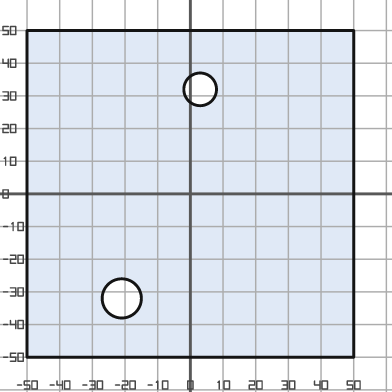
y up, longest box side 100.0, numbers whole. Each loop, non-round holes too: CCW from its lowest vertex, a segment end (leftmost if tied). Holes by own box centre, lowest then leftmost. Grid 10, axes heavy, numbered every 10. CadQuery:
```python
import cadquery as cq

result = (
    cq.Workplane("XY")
    .moveTo(-50.0, -50.0)
    .lineTo(50.0, -50.0)
    .lineTo(50.0, 50.0)
    .lineTo(-50.0, 50.0)
    .close()
    .moveTo(-21.0, -32.0)
    .circle(6.0)
    .moveTo(3.0, 32.0)
    .circle(5.0)
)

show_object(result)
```